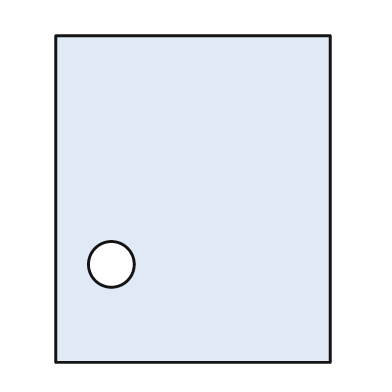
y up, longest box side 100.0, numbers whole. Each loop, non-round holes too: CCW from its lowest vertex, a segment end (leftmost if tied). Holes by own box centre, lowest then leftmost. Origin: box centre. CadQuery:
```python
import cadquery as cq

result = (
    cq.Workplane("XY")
    .moveTo(-42.0, -50.0)
    .lineTo(42.0, -50.0)
    .lineTo(42.0, 50.0)
    .lineTo(-42.0, 50.0)
    .close()
    .moveTo(-25.0, -20.0)
    .circle(7.0)
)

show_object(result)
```